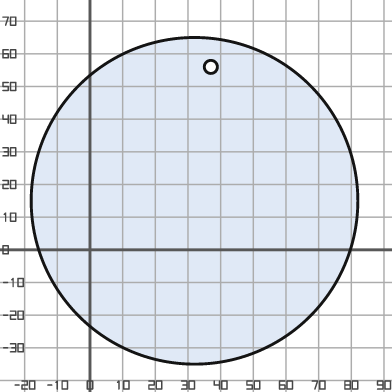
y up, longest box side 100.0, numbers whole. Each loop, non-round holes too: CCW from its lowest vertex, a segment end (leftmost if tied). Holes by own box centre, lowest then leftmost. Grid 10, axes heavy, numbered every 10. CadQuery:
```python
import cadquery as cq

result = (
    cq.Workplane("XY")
    .moveTo(32.0, 15.0)
    .circle(50.0)
    .moveTo(37.0, 56.0)
    .circle(2.0)
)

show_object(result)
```